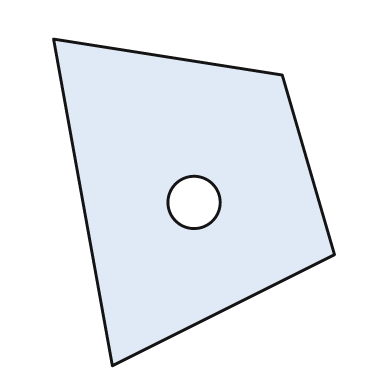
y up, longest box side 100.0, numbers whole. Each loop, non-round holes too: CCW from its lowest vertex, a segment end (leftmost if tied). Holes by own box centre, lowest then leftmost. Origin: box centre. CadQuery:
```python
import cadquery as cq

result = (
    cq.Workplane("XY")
    .moveTo(-25.0, -50.0)
    .lineTo(43.0, -16.0)
    .lineTo(27.0, 39.0)
    .lineTo(-43.0, 50.0)
    .close()
    .moveTo(0.0, 0.0)
    .circle(8.0)
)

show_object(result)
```